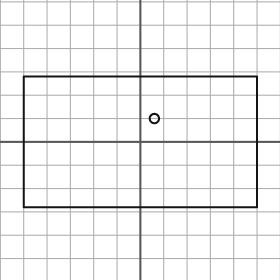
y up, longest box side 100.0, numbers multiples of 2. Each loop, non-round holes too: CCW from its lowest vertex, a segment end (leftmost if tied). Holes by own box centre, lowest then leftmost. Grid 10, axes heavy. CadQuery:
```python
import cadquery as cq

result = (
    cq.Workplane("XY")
    .moveTo(-50.0, -28.0)
    .lineTo(50.0, -28.0)
    .lineTo(50.0, 28.0)
    .lineTo(-50.0, 28.0)
    .close()
    .moveTo(6.0, 10.0)
    .circle(2.0)
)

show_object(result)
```